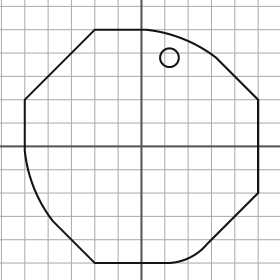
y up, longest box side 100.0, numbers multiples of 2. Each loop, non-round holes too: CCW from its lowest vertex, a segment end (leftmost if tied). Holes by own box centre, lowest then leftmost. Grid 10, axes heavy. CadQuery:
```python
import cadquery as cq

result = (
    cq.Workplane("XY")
    .moveTo(-20.0, -50.0)
    .lineTo(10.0, -50.0)
    .threePointArc((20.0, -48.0), (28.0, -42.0))
    .lineTo(50.0, -20.0)
    .lineTo(50.0, 20.0)
    .lineTo(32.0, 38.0)
    .threePointArc((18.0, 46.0), (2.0, 50.0))
    .lineTo(-20.0, 50.0)
    .lineTo(-50.0, 20.0)
    .lineTo(-50.0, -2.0)
    .threePointArc((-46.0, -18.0), (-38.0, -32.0))
    .close()
    .moveTo(12.0, 38.0)
    .circle(4.0)
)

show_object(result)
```